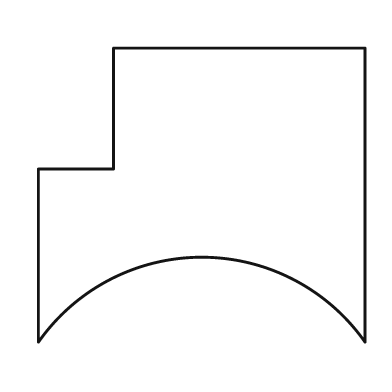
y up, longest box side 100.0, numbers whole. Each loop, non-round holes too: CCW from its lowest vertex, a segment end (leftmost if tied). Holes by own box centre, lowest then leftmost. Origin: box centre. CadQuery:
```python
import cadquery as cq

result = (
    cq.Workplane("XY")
    .moveTo(-50.0, -45.0)
    .threePointArc((0.0, -19.0), (50.0, -45.0))
    .lineTo(50.0, 45.0)
    .lineTo(-27.0, 45.0)
    .lineTo(-27.0, 8.0)
    .lineTo(-50.0, 8.0)
    .close()
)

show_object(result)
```